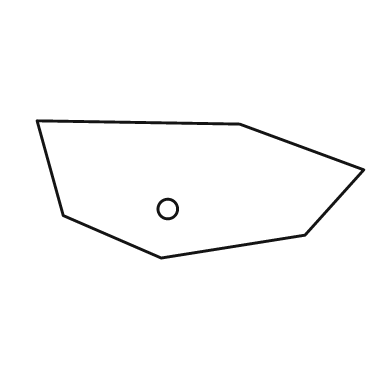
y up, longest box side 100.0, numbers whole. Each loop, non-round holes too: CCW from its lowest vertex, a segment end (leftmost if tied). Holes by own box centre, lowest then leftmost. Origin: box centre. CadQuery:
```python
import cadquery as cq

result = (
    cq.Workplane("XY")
    .moveTo(-12.0, -21.0)
    .lineTo(32.0, -14.0)
    .lineTo(50.0, 6.0)
    .lineTo(12.0, 20.0)
    .lineTo(-50.0, 21.0)
    .lineTo(-42.0, -8.0)
    .close()
    .moveTo(-10.0, -6.0)
    .circle(3.0)
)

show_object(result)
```